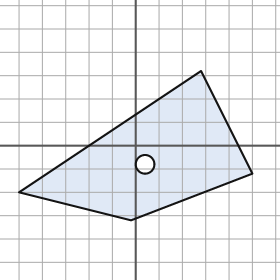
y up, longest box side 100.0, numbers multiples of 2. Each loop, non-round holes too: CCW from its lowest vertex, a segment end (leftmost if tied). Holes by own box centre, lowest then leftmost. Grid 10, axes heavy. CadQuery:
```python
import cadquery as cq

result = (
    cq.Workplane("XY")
    .moveTo(-2.0, -32.0)
    .lineTo(50.0, -12.0)
    .lineTo(28.0, 32.0)
    .lineTo(-50.0, -20.0)
    .close()
    .moveTo(4.0, -8.0)
    .circle(4.0)
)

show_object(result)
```